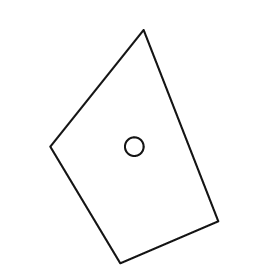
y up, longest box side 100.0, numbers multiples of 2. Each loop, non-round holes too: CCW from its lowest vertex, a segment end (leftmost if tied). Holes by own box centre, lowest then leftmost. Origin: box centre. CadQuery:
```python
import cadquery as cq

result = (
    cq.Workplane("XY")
    .moveTo(-6.0, -50.0)
    .lineTo(36.0, -32.0)
    .lineTo(4.0, 50.0)
    .lineTo(-36.0, 0.0)
    .close()
    .moveTo(0.0, 0.0)
    .circle(4.0)
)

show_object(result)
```